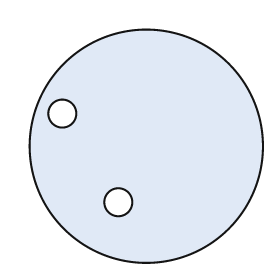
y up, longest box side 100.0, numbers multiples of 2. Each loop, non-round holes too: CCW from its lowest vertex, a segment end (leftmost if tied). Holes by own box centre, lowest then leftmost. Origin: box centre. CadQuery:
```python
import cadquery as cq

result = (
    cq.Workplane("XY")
    .moveTo(0.0, 0.0)
    .circle(50.0)
    .moveTo(-12.0, -24.0)
    .circle(6.0)
    .moveTo(-36.0, 14.0)
    .circle(6.0)
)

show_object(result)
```